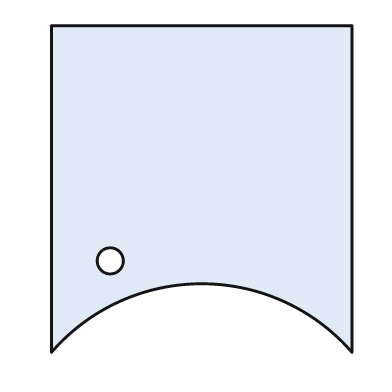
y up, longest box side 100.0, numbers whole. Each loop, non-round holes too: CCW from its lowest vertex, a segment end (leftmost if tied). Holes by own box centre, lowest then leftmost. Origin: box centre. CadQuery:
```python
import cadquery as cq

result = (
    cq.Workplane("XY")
    .moveTo(-46.0, -50.0)
    .threePointArc((0.0, -29.0), (46.0, -50.0))
    .lineTo(46.0, 50.0)
    .lineTo(-46.0, 50.0)
    .close()
    .moveTo(-28.0, -22.0)
    .circle(4.0)
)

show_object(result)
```